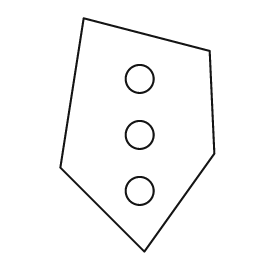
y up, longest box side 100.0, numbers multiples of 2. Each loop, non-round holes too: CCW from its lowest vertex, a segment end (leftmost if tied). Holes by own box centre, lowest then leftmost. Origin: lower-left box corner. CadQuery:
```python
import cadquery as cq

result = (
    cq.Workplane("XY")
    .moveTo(36.0, 0.0)
    .lineTo(66.0, 42.0)
    .lineTo(64.0, 86.0)
    .lineTo(10.0, 100.0)
    .lineTo(0.0, 36.0)
    .close()
    .moveTo(34.0, 26.0)
    .circle(6.0)
    .moveTo(34.0, 50.0)
    .circle(6.0)
    .moveTo(34.0, 74.0)
    .circle(6.0)
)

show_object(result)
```